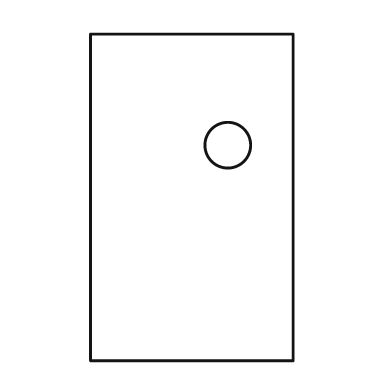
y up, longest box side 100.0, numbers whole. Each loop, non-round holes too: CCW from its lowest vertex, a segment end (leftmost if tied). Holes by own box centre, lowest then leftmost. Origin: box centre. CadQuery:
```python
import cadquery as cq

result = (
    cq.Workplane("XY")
    .moveTo(-31.0, -50.0)
    .lineTo(31.0, -50.0)
    .lineTo(31.0, 50.0)
    .lineTo(-31.0, 50.0)
    .close()
    .moveTo(11.0, 16.0)
    .circle(7.0)
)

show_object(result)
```